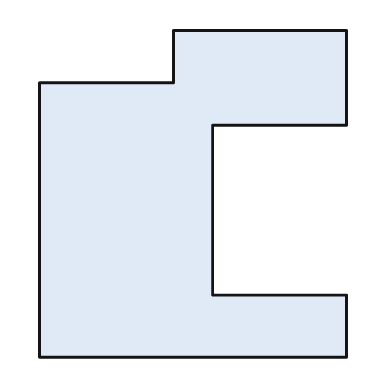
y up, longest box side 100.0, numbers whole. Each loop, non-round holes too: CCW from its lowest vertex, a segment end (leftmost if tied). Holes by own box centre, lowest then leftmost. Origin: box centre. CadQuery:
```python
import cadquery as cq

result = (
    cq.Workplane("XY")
    .moveTo(-47.0, -50.0)
    .lineTo(47.0, -50.0)
    .lineTo(47.0, -31.0)
    .lineTo(6.0, -31.0)
    .lineTo(6.0, 21.0)
    .lineTo(47.0, 21.0)
    .lineTo(47.0, 50.0)
    .lineTo(-6.0, 50.0)
    .lineTo(-6.0, 34.0)
    .lineTo(-47.0, 34.0)
    .close()
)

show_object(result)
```